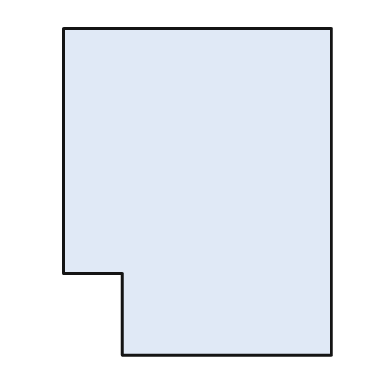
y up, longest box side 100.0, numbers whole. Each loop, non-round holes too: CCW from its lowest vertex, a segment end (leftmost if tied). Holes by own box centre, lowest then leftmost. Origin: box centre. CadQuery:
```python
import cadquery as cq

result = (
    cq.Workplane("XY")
    .moveTo(-23.0, -50.0)
    .lineTo(41.0, -50.0)
    .lineTo(41.0, 50.0)
    .lineTo(-41.0, 50.0)
    .lineTo(-41.0, -25.0)
    .lineTo(-23.0, -25.0)
    .close()
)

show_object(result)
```